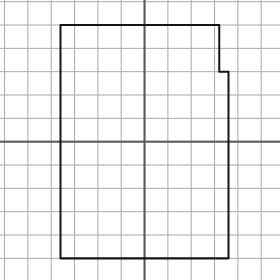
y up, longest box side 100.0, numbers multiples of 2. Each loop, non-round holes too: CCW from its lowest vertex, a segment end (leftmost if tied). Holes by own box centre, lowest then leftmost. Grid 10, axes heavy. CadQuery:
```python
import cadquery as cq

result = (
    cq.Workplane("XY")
    .moveTo(-36.0, -50.0)
    .lineTo(36.0, -50.0)
    .lineTo(36.0, 30.0)
    .lineTo(32.0, 30.0)
    .lineTo(32.0, 50.0)
    .lineTo(-36.0, 50.0)
    .close()
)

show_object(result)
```